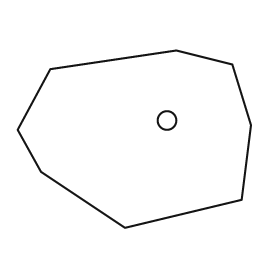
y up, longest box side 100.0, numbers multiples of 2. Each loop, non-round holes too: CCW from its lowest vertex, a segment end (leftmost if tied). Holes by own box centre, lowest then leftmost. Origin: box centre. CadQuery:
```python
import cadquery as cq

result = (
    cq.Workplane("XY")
    .moveTo(-4.0, -38.0)
    .lineTo(46.0, -26.0)
    .lineTo(50.0, 6.0)
    .lineTo(42.0, 32.0)
    .lineTo(18.0, 38.0)
    .lineTo(-36.0, 30.0)
    .lineTo(-50.0, 4.0)
    .lineTo(-40.0, -14.0)
    .close()
    .moveTo(14.0, 8.0)
    .circle(4.0)
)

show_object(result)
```